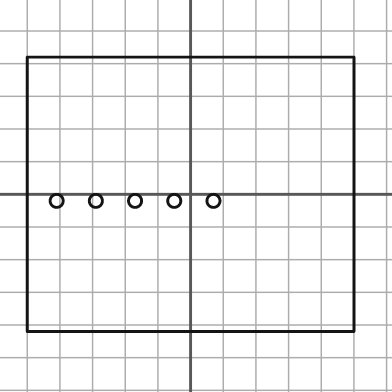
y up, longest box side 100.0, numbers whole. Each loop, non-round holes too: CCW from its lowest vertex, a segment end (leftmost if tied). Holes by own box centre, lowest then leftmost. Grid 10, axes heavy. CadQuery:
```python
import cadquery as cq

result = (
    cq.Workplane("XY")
    .moveTo(-50.0, -42.0)
    .lineTo(50.0, -42.0)
    .lineTo(50.0, 42.0)
    .lineTo(-50.0, 42.0)
    .close()
    .moveTo(-41.0, -2.0)
    .circle(2.0)
    .moveTo(-29.0, -2.0)
    .circle(2.0)
    .moveTo(-17.0, -2.0)
    .circle(2.0)
    .moveTo(-5.0, -2.0)
    .circle(2.0)
    .moveTo(7.0, -2.0)
    .circle(2.0)
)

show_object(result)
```